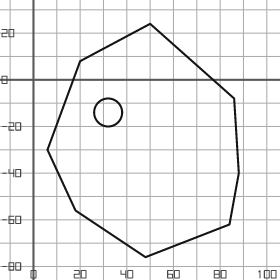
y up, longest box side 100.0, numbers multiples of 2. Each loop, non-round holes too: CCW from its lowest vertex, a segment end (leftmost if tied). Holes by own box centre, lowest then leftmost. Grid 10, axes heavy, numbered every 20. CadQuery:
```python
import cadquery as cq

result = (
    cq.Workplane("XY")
    .moveTo(48.0, -76.0)
    .lineTo(84.0, -62.0)
    .lineTo(88.0, -40.0)
    .lineTo(86.0, -8.0)
    .lineTo(50.0, 24.0)
    .lineTo(20.0, 8.0)
    .lineTo(6.0, -30.0)
    .lineTo(18.0, -56.0)
    .close()
    .moveTo(32.0, -14.0)
    .circle(6.0)
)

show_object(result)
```